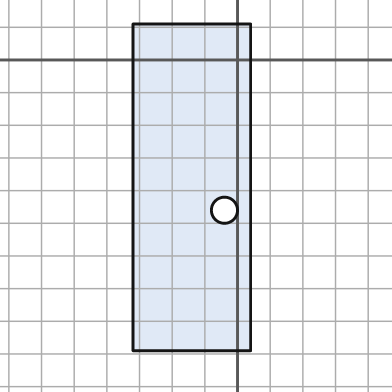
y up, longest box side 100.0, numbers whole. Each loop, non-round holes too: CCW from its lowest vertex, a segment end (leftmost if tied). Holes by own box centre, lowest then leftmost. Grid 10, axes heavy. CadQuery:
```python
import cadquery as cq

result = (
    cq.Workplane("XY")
    .moveTo(-32.0, -89.0)
    .lineTo(4.0, -89.0)
    .lineTo(4.0, 11.0)
    .lineTo(-32.0, 11.0)
    .close()
    .moveTo(-4.0, -46.0)
    .circle(4.0)
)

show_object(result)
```